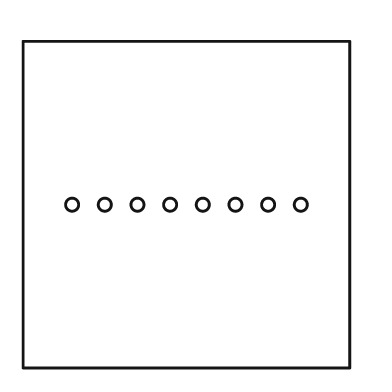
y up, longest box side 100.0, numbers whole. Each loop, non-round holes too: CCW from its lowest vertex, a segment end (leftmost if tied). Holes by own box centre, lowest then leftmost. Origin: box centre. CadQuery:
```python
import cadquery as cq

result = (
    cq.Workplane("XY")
    .moveTo(-50.0, -50.0)
    .lineTo(50.0, -50.0)
    .lineTo(50.0, 50.0)
    .lineTo(-50.0, 50.0)
    .close()
    .moveTo(-35.0, 0.0)
    .circle(2.0)
    .moveTo(-25.0, 0.0)
    .circle(2.0)
    .moveTo(-15.0, 0.0)
    .circle(2.0)
    .moveTo(-5.0, 0.0)
    .circle(2.0)
    .moveTo(5.0, 0.0)
    .circle(2.0)
    .moveTo(15.0, 0.0)
    .circle(2.0)
    .moveTo(25.0, 0.0)
    .circle(2.0)
    .moveTo(35.0, 0.0)
    .circle(2.0)
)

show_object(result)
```